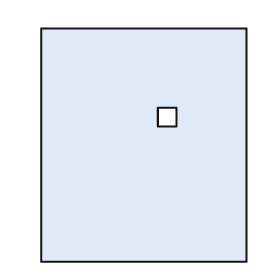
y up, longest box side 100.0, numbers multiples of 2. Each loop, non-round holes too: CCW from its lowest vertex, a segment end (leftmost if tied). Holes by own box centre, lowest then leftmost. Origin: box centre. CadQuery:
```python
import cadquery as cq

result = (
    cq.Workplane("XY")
    .moveTo(-44.0, -50.0)
    .lineTo(44.0, -50.0)
    .lineTo(44.0, 50.0)
    .lineTo(-44.0, 50.0)
    .close()
    .moveTo(6.0, 8.0)
    .lineTo(14.0, 8.0)
    .lineTo(14.0, 16.0)
    .lineTo(6.0, 16.0)
    .close()
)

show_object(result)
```